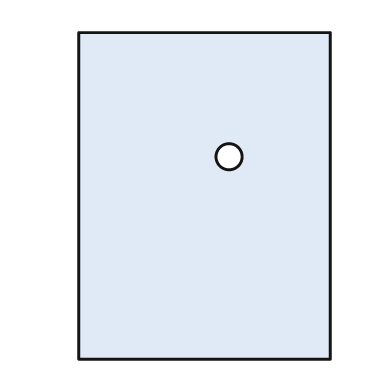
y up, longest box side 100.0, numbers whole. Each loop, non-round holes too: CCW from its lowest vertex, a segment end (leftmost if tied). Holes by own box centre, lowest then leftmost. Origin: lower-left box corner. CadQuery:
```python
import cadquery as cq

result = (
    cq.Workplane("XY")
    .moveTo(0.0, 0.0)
    .lineTo(77.0, 0.0)
    .lineTo(77.0, 100.0)
    .lineTo(0.0, 100.0)
    .close()
    .moveTo(46.0, 62.0)
    .circle(4.0)
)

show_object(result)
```